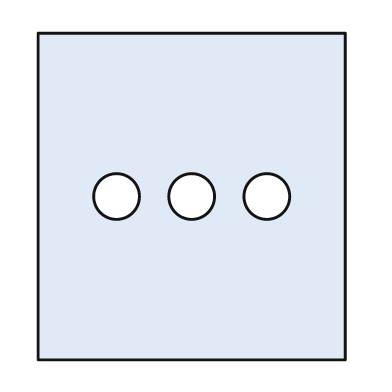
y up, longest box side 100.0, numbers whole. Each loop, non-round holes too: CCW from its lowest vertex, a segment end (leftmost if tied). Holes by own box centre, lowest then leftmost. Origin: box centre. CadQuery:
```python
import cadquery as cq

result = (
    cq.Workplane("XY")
    .moveTo(-47.0, -50.0)
    .lineTo(47.0, -50.0)
    .lineTo(47.0, 50.0)
    .lineTo(-47.0, 50.0)
    .close()
    .moveTo(-23.0, 0.0)
    .circle(7.0)
    .moveTo(0.0, 0.0)
    .circle(7.0)
    .moveTo(23.0, 0.0)
    .circle(7.0)
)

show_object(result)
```